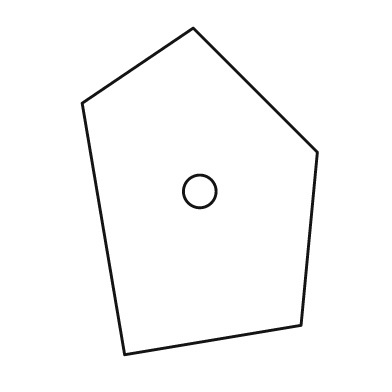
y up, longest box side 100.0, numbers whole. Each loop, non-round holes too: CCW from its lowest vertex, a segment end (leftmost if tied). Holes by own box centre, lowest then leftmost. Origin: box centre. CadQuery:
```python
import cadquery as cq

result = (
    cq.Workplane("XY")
    .moveTo(-23.0, -50.0)
    .lineTo(31.0, -41.0)
    .lineTo(36.0, 12.0)
    .lineTo(-2.0, 50.0)
    .lineTo(-36.0, 27.0)
    .close()
    .moveTo(0.0, 0.0)
    .circle(5.0)
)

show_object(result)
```